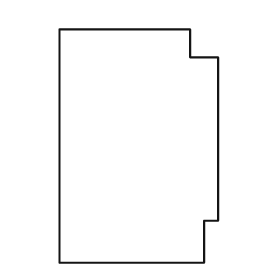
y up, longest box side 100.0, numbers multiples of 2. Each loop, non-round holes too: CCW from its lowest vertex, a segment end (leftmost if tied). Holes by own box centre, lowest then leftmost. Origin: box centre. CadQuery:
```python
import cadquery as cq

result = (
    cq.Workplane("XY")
    .moveTo(-34.0, -50.0)
    .lineTo(28.0, -50.0)
    .lineTo(28.0, -32.0)
    .lineTo(34.0, -32.0)
    .lineTo(34.0, 38.0)
    .lineTo(22.0, 38.0)
    .lineTo(22.0, 50.0)
    .lineTo(-34.0, 50.0)
    .close()
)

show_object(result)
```